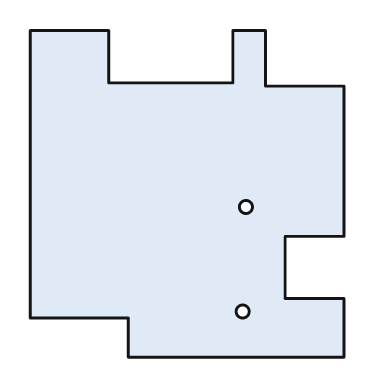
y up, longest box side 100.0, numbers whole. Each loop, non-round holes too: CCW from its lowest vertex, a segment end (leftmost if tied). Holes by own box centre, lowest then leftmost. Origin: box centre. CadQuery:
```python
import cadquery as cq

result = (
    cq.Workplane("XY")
    .moveTo(-18.0, -50.0)
    .lineTo(48.0, -50.0)
    .lineTo(48.0, -32.0)
    .lineTo(30.0, -32.0)
    .lineTo(30.0, -13.0)
    .lineTo(48.0, -13.0)
    .lineTo(48.0, 33.0)
    .lineTo(24.0, 33.0)
    .lineTo(24.0, 50.0)
    .lineTo(14.0, 50.0)
    .lineTo(14.0, 34.0)
    .lineTo(-24.0, 34.0)
    .lineTo(-24.0, 50.0)
    .lineTo(-48.0, 50.0)
    .lineTo(-48.0, -38.0)
    .lineTo(-18.0, -38.0)
    .close()
    .moveTo(17.0, -36.0)
    .circle(2.0)
    .moveTo(18.0, -4.0)
    .circle(2.0)
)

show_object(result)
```